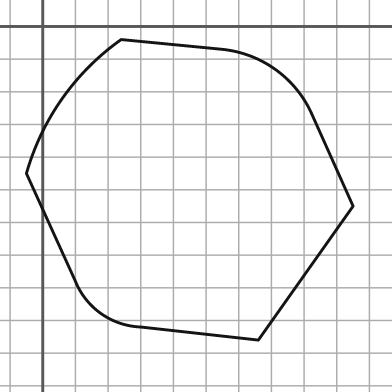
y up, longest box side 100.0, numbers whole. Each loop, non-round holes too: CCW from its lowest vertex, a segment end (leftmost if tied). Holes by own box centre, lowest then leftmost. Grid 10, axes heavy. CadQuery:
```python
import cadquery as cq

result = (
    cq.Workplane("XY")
    .moveTo(66.0, -96.0)
    .lineTo(95.0, -55.0)
    .lineTo(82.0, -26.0)
    .threePointArc((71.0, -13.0), (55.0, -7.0))
    .lineTo(24.0, -4.0)
    .threePointArc((6.0, -22.0), (-5.0, -45.0))
    .lineTo(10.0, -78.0)
    .threePointArc((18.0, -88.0), (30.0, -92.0))
    .close()
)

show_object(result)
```